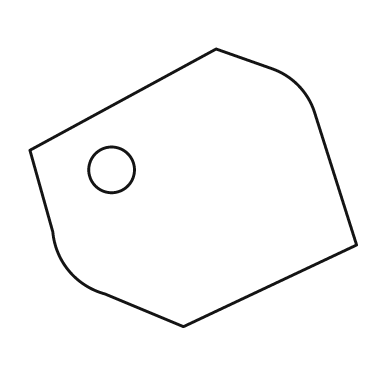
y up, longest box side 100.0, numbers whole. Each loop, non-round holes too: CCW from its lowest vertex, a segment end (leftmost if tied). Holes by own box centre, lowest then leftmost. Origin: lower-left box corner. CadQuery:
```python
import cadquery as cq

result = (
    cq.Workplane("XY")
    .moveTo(47.0, 0.0)
    .lineTo(100.0, 25.0)
    .lineTo(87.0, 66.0)
    .threePointArc((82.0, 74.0), (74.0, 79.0))
    .lineTo(57.0, 85.0)
    .lineTo(0.0, 54.0)
    .lineTo(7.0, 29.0)
    .threePointArc((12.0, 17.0), (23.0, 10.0))
    .close()
    .moveTo(25.0, 48.0)
    .circle(7.0)
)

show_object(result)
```